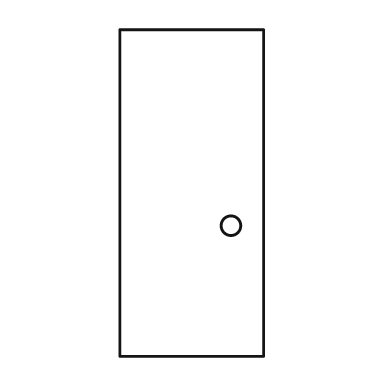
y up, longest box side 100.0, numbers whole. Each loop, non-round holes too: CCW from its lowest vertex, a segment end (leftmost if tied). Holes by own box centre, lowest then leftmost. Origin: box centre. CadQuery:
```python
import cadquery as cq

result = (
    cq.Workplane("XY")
    .moveTo(-22.0, -50.0)
    .lineTo(22.0, -50.0)
    .lineTo(22.0, 50.0)
    .lineTo(-22.0, 50.0)
    .close()
    .moveTo(12.0, -10.0)
    .circle(3.0)
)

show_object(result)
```